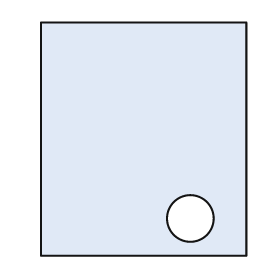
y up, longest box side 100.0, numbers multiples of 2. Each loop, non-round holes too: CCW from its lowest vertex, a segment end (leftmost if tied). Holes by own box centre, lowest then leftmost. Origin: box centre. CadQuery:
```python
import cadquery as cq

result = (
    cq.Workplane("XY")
    .moveTo(-44.0, -50.0)
    .lineTo(44.0, -50.0)
    .lineTo(44.0, 50.0)
    .lineTo(-44.0, 50.0)
    .close()
    .moveTo(20.0, -34.0)
    .circle(10.0)
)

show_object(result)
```